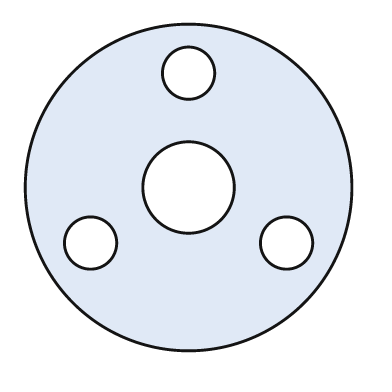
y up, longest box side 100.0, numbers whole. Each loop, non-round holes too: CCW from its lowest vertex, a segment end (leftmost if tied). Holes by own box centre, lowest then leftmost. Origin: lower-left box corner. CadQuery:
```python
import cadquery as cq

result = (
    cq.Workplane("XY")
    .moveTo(50.0, 50.0)
    .circle(50.0)
    .moveTo(20.0, 33.0)
    .circle(8.0)
    .moveTo(80.0, 33.0)
    .circle(8.0)
    .moveTo(50.0, 50.0)
    .circle(14.0)
    .moveTo(50.0, 85.0)
    .circle(8.0)
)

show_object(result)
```